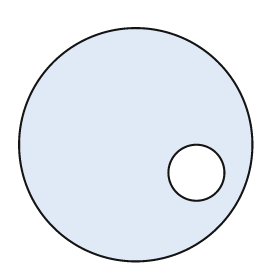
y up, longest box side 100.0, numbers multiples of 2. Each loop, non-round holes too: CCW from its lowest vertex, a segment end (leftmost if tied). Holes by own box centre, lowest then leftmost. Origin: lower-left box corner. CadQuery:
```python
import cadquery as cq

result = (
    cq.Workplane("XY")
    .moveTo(50.0, 50.0)
    .circle(50.0)
    .moveTo(76.0, 38.0)
    .circle(12.0)
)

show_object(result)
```